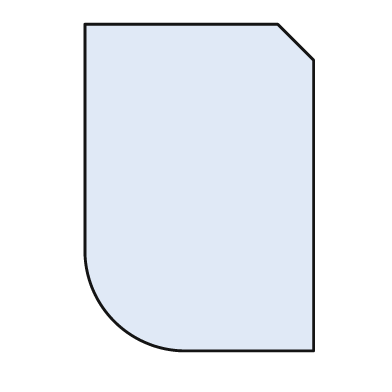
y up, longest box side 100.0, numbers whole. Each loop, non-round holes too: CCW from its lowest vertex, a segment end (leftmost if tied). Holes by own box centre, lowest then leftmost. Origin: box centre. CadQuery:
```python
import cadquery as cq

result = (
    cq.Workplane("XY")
    .moveTo(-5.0, -50.0)
    .lineTo(35.0, -50.0)
    .lineTo(35.0, 39.0)
    .lineTo(24.0, 50.0)
    .lineTo(-35.0, 50.0)
    .lineTo(-35.0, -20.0)
    .threePointArc((-26.0, -41.0), (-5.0, -50.0))
    .close()
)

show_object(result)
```